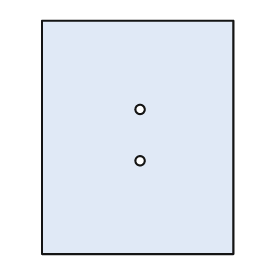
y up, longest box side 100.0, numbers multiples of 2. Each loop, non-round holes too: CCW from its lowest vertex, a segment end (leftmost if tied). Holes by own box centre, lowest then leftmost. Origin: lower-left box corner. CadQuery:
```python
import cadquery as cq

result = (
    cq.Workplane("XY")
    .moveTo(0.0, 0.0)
    .lineTo(82.0, 0.0)
    .lineTo(82.0, 100.0)
    .lineTo(0.0, 100.0)
    .close()
    .moveTo(42.0, 40.0)
    .circle(2.0)
    .moveTo(42.0, 62.0)
    .circle(2.0)
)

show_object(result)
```